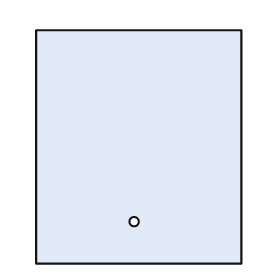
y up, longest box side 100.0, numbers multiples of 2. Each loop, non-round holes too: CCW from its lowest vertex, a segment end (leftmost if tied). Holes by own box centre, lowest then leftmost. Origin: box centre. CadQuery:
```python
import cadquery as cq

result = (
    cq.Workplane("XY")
    .moveTo(-44.0, -50.0)
    .lineTo(44.0, -50.0)
    .lineTo(44.0, 50.0)
    .lineTo(-44.0, 50.0)
    .close()
    .moveTo(-2.0, -32.0)
    .circle(2.0)
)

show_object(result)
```